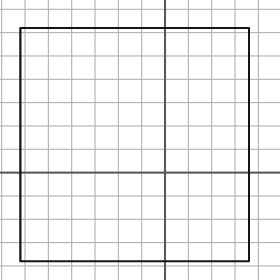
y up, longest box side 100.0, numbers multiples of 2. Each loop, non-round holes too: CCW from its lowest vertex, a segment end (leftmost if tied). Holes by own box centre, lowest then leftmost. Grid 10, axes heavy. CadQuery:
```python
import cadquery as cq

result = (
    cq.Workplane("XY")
    .moveTo(-62.0, -38.0)
    .lineTo(36.0, -38.0)
    .lineTo(36.0, 62.0)
    .lineTo(-62.0, 62.0)
    .close()
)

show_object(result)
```